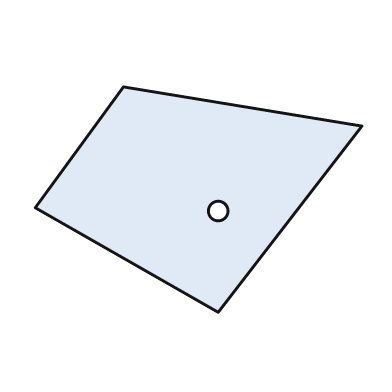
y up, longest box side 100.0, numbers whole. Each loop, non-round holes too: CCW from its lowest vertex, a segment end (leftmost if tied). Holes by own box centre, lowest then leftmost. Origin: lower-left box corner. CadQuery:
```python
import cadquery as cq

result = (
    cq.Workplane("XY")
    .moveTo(56.0, 0.0)
    .lineTo(100.0, 57.0)
    .lineTo(27.0, 69.0)
    .lineTo(0.0, 32.0)
    .close()
    .moveTo(56.0, 31.0)
    .circle(3.0)
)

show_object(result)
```